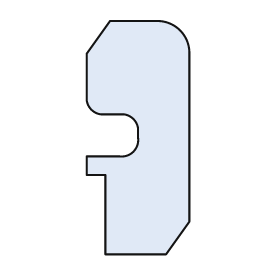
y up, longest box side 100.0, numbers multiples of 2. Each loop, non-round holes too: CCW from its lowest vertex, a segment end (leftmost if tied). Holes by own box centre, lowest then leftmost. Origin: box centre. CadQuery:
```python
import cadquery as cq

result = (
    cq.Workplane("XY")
    .moveTo(-14.0, -50.0)
    .lineTo(12.0, -50.0)
    .lineTo(22.0, -36.0)
    .lineTo(22.0, 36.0)
    .threePointArc((18.0, 46.0), (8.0, 50.0))
    .lineTo(-12.0, 50.0)
    .lineTo(-22.0, 36.0)
    .lineTo(-22.0, 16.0)
    .threePointArc((-20.0, 12.0), (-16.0, 10.0))
    .lineTo(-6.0, 10.0)
    .threePointArc((-2.0, 8.0), (0.0, 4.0))
    .lineTo(0.0, 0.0)
    .threePointArc((-2.0, -6.0), (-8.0, -8.0))
    .lineTo(-22.0, -8.0)
    .lineTo(-22.0, -16.0)
    .lineTo(-14.0, -16.0)
    .close()
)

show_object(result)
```